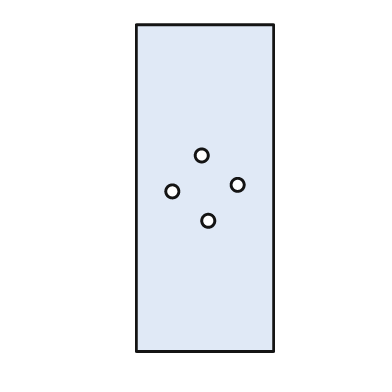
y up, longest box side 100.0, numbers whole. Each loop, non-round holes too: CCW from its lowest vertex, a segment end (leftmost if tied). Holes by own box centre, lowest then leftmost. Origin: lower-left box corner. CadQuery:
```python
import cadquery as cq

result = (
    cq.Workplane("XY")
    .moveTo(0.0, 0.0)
    .lineTo(42.0, 0.0)
    .lineTo(42.0, 100.0)
    .lineTo(0.0, 100.0)
    .close()
    .moveTo(22.0, 40.0)
    .circle(2.0)
    .moveTo(11.0, 49.0)
    .circle(2.0)
    .moveTo(31.0, 51.0)
    .circle(2.0)
    .moveTo(20.0, 60.0)
    .circle(2.0)
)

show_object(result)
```